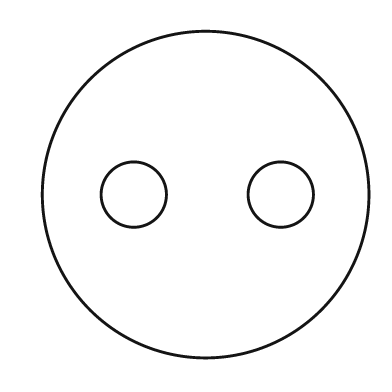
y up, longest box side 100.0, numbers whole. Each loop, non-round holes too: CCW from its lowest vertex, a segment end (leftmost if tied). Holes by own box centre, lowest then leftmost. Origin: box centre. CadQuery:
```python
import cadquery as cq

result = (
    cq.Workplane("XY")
    .moveTo(0.0, 0.0)
    .circle(50.0)
    .moveTo(-22.0, 0.0)
    .circle(10.0)
    .moveTo(23.0, 0.0)
    .circle(10.0)
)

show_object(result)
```